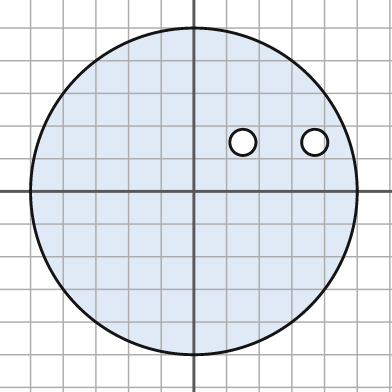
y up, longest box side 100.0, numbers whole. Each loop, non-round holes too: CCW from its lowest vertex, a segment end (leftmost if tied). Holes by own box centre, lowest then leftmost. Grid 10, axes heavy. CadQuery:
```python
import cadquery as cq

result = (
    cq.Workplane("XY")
    .moveTo(0.0, 0.0)
    .circle(50.0)
    .moveTo(15.0, 15.0)
    .circle(4.0)
    .moveTo(37.0, 15.0)
    .circle(4.0)
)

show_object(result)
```